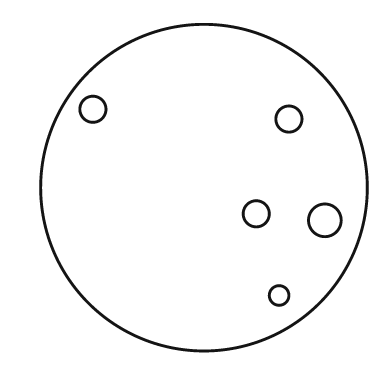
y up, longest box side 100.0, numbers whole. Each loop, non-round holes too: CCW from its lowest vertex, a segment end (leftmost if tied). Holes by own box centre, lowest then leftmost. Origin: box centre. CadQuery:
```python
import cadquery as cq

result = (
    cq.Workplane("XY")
    .moveTo(0.0, 0.0)
    .circle(50.0)
    .moveTo(23.0, -33.0)
    .circle(3.0)
    .moveTo(37.0, -10.0)
    .circle(5.0)
    .moveTo(16.0, -8.0)
    .circle(4.0)
    .moveTo(26.0, 21.0)
    .circle(4.0)
    .moveTo(-34.0, 24.0)
    .circle(4.0)
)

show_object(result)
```